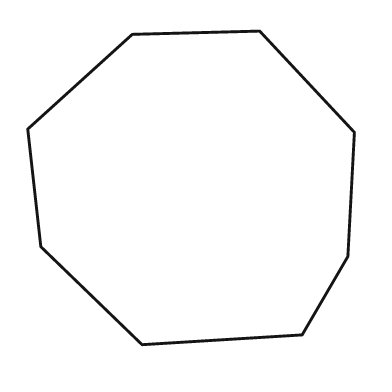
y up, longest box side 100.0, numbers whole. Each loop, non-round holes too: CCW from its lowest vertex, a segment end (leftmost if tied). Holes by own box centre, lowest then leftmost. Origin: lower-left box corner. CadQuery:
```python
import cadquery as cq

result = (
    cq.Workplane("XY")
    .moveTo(35.0, 0.0)
    .lineTo(84.0, 3.0)
    .lineTo(98.0, 27.0)
    .lineTo(100.0, 65.0)
    .lineTo(71.0, 96.0)
    .lineTo(32.0, 95.0)
    .lineTo(0.0, 66.0)
    .lineTo(4.0, 30.0)
    .close()
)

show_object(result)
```